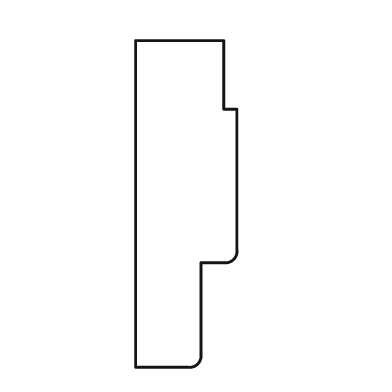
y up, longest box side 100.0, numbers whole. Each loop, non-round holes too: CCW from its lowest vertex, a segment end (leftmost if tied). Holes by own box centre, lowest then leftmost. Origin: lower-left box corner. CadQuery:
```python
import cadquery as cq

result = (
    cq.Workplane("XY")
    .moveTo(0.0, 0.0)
    .lineTo(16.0, 0.0)
    .threePointArc((19.0, 1.0), (20.0, 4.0))
    .lineTo(20.0, 32.0)
    .lineTo(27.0, 32.0)
    .threePointArc((30.0, 33.0), (31.0, 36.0))
    .lineTo(31.0, 79.0)
    .lineTo(27.0, 79.0)
    .lineTo(27.0, 100.0)
    .lineTo(0.0, 100.0)
    .close()
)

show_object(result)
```